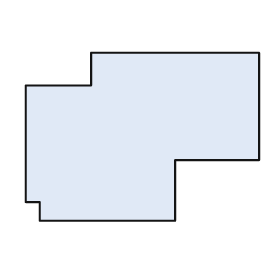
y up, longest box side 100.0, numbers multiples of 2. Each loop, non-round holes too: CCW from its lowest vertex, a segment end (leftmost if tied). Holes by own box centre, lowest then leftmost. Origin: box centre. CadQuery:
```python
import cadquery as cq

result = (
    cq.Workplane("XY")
    .moveTo(-44.0, -36.0)
    .lineTo(14.0, -36.0)
    .lineTo(14.0, -10.0)
    .lineTo(50.0, -10.0)
    .lineTo(50.0, 36.0)
    .lineTo(-22.0, 36.0)
    .lineTo(-22.0, 22.0)
    .lineTo(-50.0, 22.0)
    .lineTo(-50.0, -28.0)
    .lineTo(-44.0, -28.0)
    .close()
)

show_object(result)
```